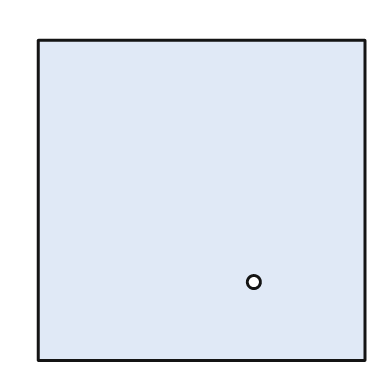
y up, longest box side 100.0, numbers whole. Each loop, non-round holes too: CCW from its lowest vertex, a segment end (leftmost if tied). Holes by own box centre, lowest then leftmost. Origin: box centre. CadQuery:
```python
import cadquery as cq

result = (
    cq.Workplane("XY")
    .moveTo(-50.0, -49.0)
    .lineTo(50.0, -49.0)
    .lineTo(50.0, 49.0)
    .lineTo(-50.0, 49.0)
    .close()
    .moveTo(16.0, -25.0)
    .circle(2.0)
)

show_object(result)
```